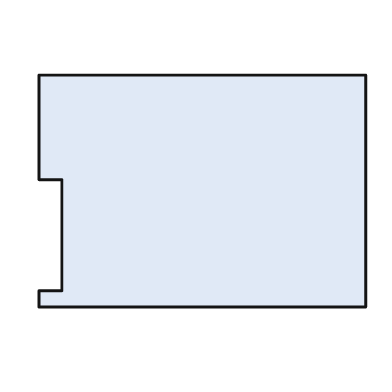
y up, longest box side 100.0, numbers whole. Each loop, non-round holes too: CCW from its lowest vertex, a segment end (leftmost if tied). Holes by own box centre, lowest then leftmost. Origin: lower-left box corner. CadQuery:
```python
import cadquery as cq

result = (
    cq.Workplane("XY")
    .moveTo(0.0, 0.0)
    .lineTo(100.0, 0.0)
    .lineTo(100.0, 71.0)
    .lineTo(0.0, 71.0)
    .lineTo(0.0, 39.0)
    .lineTo(7.0, 39.0)
    .lineTo(7.0, 5.0)
    .lineTo(0.0, 5.0)
    .close()
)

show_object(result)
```